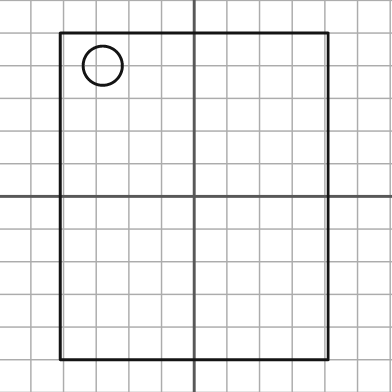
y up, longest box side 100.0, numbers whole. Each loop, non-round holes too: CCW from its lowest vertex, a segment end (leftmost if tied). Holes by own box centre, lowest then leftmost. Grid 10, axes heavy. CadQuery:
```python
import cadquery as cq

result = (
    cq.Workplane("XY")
    .moveTo(-41.0, -50.0)
    .lineTo(41.0, -50.0)
    .lineTo(41.0, 50.0)
    .lineTo(-41.0, 50.0)
    .close()
    .moveTo(-28.0, 40.0)
    .circle(6.0)
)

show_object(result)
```